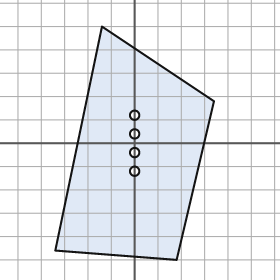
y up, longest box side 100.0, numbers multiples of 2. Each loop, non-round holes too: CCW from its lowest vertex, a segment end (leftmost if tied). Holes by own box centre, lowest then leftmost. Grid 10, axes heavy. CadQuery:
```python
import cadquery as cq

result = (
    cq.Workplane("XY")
    .moveTo(18.0, -50.0)
    .lineTo(34.0, 18.0)
    .lineTo(-14.0, 50.0)
    .lineTo(-34.0, -46.0)
    .close()
    .moveTo(0.0, -12.0)
    .circle(2.0)
    .moveTo(0.0, -4.0)
    .circle(2.0)
    .moveTo(0.0, 4.0)
    .circle(2.0)
    .moveTo(0.0, 12.0)
    .circle(2.0)
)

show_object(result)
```